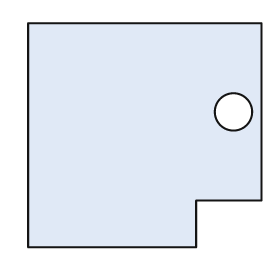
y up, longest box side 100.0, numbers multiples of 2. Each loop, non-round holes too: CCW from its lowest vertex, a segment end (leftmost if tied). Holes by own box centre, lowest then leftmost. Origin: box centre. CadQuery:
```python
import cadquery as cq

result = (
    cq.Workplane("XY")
    .moveTo(-50.0, -48.0)
    .lineTo(22.0, -48.0)
    .lineTo(22.0, -28.0)
    .lineTo(50.0, -28.0)
    .lineTo(50.0, 48.0)
    .lineTo(-50.0, 48.0)
    .close()
    .moveTo(38.0, 10.0)
    .circle(8.0)
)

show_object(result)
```